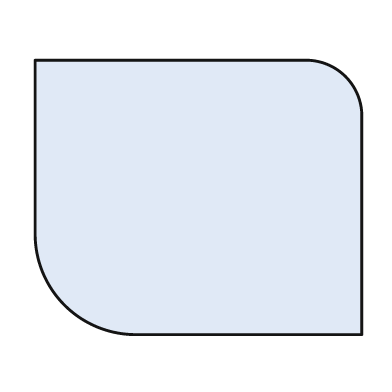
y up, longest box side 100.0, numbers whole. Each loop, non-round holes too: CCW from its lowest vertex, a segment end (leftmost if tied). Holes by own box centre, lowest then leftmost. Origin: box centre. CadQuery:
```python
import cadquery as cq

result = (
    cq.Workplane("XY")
    .moveTo(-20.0, -42.0)
    .lineTo(50.0, -42.0)
    .lineTo(50.0, 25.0)
    .threePointArc((45.0, 37.0), (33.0, 42.0))
    .lineTo(-50.0, 42.0)
    .lineTo(-50.0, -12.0)
    .threePointArc((-41.0, -33.0), (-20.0, -42.0))
    .close()
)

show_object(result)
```